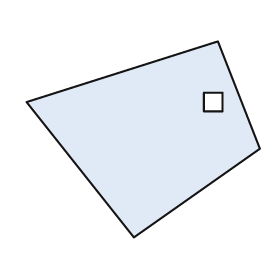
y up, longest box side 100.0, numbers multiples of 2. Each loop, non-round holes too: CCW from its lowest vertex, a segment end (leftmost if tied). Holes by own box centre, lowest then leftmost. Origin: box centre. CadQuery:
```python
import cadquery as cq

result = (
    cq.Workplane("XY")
    .moveTo(-4.0, -42.0)
    .lineTo(50.0, -4.0)
    .lineTo(32.0, 42.0)
    .lineTo(-50.0, 16.0)
    .close()
    .moveTo(26.0, 12.0)
    .lineTo(34.0, 12.0)
    .lineTo(34.0, 20.0)
    .lineTo(26.0, 20.0)
    .close()
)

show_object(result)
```